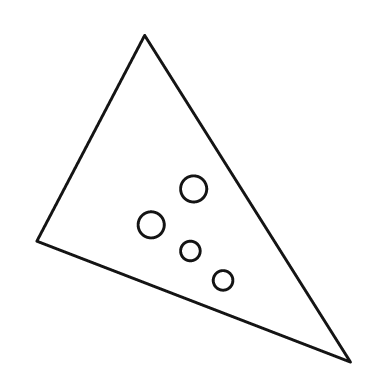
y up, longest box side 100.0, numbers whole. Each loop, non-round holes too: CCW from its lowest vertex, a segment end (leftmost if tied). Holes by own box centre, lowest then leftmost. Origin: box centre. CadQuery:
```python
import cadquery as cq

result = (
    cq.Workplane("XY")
    .moveTo(48.0, -50.0)
    .lineTo(-15.0, 50.0)
    .lineTo(-48.0, -13.0)
    .close()
    .moveTo(9.0, -25.0)
    .circle(3.0)
    .moveTo(-1.0, -16.0)
    .circle(3.0)
    .moveTo(-13.0, -8.0)
    .circle(4.0)
    .moveTo(0.0, 3.0)
    .circle(4.0)
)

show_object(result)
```